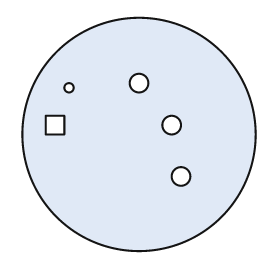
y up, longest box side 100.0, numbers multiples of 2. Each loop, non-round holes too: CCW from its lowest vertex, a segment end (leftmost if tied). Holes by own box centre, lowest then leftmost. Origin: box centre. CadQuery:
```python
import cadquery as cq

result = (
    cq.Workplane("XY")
    .moveTo(0.0, 0.0)
    .circle(50.0)
    .moveTo(18.0, -18.0)
    .circle(4.0)
    .moveTo(-40.0, 0.0)
    .lineTo(-32.0, 0.0)
    .lineTo(-32.0, 8.0)
    .lineTo(-40.0, 8.0)
    .close()
    .moveTo(14.0, 4.0)
    .circle(4.0)
    .moveTo(-30.0, 20.0)
    .circle(2.0)
    .moveTo(0.0, 22.0)
    .circle(4.0)
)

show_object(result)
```